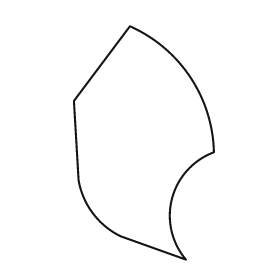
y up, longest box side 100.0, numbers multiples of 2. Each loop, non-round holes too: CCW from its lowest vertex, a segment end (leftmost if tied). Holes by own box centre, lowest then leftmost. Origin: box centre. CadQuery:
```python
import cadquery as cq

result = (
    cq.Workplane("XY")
    .moveTo(18.0, -50.0)
    .threePointArc((12.0, -24.0), (30.0, -4.0))
    .threePointArc((20.0, 28.0), (-6.0, 50.0))
    .lineTo(-30.0, 18.0)
    .lineTo(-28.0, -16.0)
    .threePointArc((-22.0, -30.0), (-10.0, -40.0))
    .close()
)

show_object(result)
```